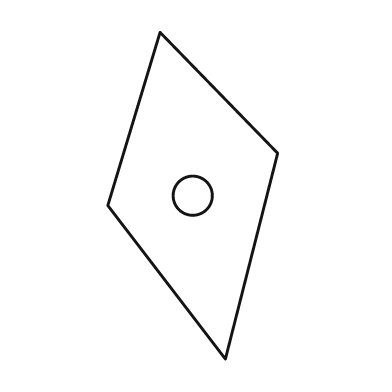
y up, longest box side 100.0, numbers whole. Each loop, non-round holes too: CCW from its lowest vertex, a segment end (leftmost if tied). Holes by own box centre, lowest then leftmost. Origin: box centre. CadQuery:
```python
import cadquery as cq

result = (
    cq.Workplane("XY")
    .moveTo(10.0, -50.0)
    .lineTo(26.0, 13.0)
    .lineTo(-10.0, 50.0)
    .lineTo(-26.0, -3.0)
    .close()
    .moveTo(0.0, 0.0)
    .circle(6.0)
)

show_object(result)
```